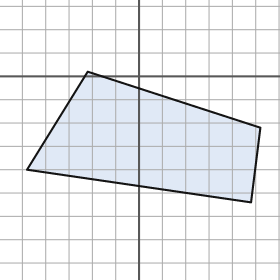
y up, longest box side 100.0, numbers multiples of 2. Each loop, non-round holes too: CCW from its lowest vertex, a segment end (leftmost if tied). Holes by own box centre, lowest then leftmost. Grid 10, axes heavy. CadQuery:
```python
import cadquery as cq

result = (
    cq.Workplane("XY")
    .moveTo(48.0, -54.0)
    .lineTo(52.0, -22.0)
    .lineTo(-22.0, 2.0)
    .lineTo(-48.0, -40.0)
    .close()
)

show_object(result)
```